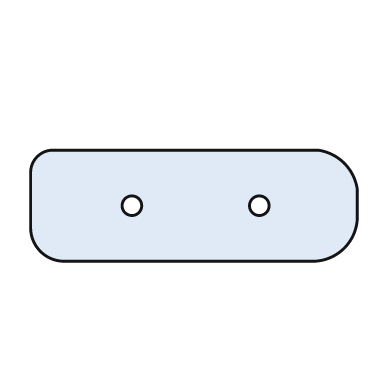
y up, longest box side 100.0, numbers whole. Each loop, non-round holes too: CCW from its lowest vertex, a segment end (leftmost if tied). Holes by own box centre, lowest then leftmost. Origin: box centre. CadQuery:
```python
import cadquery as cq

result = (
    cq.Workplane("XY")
    .moveTo(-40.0, -17.0)
    .lineTo(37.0, -17.0)
    .threePointArc((46.0, -13.0), (50.0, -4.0))
    .lineTo(50.0, 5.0)
    .threePointArc((46.0, 13.0), (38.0, 17.0))
    .lineTo(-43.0, 17.0)
    .threePointArc((-48.0, 15.0), (-50.0, 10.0))
    .lineTo(-50.0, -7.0)
    .threePointArc((-47.0, -14.0), (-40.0, -17.0))
    .close()
    .moveTo(-19.0, 0.0)
    .circle(3.0)
    .moveTo(20.0, 0.0)
    .circle(3.0)
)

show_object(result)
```